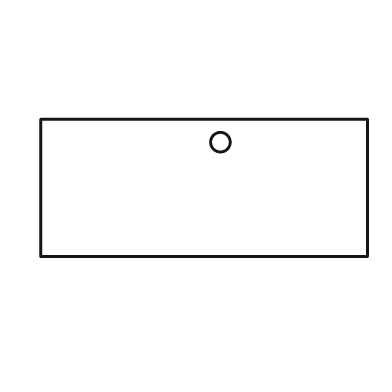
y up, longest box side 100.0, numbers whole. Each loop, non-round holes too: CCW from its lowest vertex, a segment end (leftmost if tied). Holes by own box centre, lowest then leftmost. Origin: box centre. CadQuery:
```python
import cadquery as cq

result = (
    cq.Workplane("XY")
    .moveTo(-50.0, -21.0)
    .lineTo(50.0, -21.0)
    .lineTo(50.0, 21.0)
    .lineTo(-50.0, 21.0)
    .close()
    .moveTo(5.0, 14.0)
    .circle(3.0)
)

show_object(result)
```